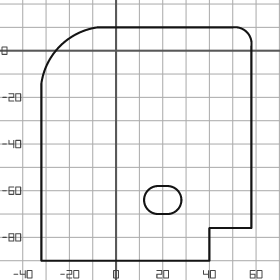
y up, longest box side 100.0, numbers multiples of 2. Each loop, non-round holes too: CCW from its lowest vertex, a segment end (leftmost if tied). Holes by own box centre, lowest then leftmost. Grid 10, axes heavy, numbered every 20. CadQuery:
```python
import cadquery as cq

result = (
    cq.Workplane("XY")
    .moveTo(-32.0, -90.0)
    .lineTo(40.0, -90.0)
    .lineTo(40.0, -76.0)
    .lineTo(58.0, -76.0)
    .lineTo(58.0, 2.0)
    .threePointArc((56.0, 8.0), (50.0, 10.0))
    .lineTo(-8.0, 10.0)
    .threePointArc((-24.0, 2.0), (-32.0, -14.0))
    .close()
    .moveTo(18.0, -70.0)
    .lineTo(22.0, -70.0)
    .threePointArc((28.0, -64.0), (22.0, -58.0))
    .lineTo(18.0, -58.0)
    .threePointArc((12.0, -64.0), (18.0, -70.0))
    .close()
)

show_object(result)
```